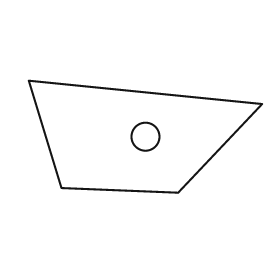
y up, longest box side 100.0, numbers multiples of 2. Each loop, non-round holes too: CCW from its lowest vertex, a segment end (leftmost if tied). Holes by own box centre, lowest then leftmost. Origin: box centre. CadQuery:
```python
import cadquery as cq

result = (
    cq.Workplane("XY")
    .moveTo(14.0, -24.0)
    .lineTo(50.0, 14.0)
    .lineTo(-50.0, 24.0)
    .lineTo(-36.0, -22.0)
    .close()
    .moveTo(0.0, 0.0)
    .circle(6.0)
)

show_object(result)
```